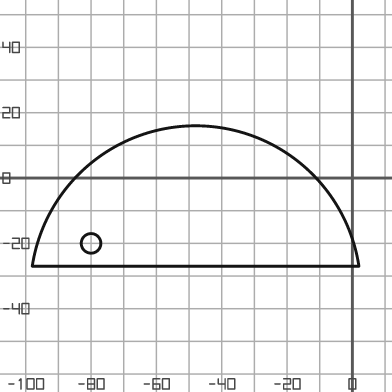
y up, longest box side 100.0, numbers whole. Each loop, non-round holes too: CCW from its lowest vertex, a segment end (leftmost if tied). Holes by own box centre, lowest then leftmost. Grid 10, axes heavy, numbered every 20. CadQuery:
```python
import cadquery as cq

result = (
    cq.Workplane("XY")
    .moveTo(-98.0, -27.0)
    .lineTo(2.0, -27.0)
    .threePointArc((-48.0, 16.0), (-98.0, -27.0))
    .close()
    .moveTo(-80.0, -20.0)
    .circle(3.0)
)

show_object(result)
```